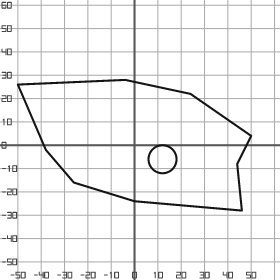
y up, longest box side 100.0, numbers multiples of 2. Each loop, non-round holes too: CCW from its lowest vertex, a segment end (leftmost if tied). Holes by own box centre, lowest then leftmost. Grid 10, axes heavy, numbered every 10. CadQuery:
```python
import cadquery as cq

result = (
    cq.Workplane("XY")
    .moveTo(46.0, -28.0)
    .lineTo(44.0, -8.0)
    .lineTo(50.0, 4.0)
    .lineTo(24.0, 22.0)
    .lineTo(-4.0, 28.0)
    .lineTo(-50.0, 26.0)
    .lineTo(-38.0, -2.0)
    .lineTo(-26.0, -16.0)
    .lineTo(0.0, -24.0)
    .close()
    .moveTo(12.0, -6.0)
    .circle(6.0)
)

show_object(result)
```